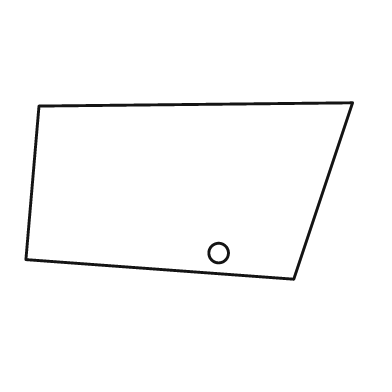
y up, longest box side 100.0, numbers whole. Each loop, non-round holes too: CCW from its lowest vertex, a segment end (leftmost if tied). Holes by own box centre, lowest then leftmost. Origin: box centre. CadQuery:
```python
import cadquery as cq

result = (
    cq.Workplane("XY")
    .moveTo(32.0, -27.0)
    .lineTo(50.0, 27.0)
    .lineTo(-46.0, 26.0)
    .lineTo(-50.0, -21.0)
    .close()
    .moveTo(9.0, -19.0)
    .circle(3.0)
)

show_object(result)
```